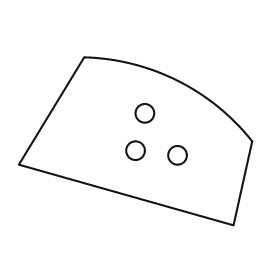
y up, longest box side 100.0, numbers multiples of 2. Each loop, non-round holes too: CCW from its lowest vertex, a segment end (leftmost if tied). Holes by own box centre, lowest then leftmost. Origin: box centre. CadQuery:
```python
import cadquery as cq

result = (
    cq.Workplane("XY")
    .moveTo(42.0, -36.0)
    .lineTo(50.0, 0.0)
    .threePointArc((18.0, 26.0), (-22.0, 36.0))
    .lineTo(-50.0, -10.0)
    .close()
    .moveTo(18.0, -6.0)
    .circle(4.0)
    .moveTo(0.0, -4.0)
    .circle(4.0)
    .moveTo(4.0, 12.0)
    .circle(4.0)
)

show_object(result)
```